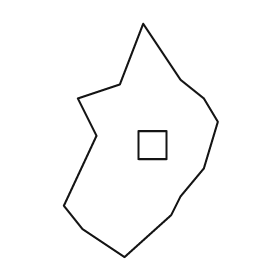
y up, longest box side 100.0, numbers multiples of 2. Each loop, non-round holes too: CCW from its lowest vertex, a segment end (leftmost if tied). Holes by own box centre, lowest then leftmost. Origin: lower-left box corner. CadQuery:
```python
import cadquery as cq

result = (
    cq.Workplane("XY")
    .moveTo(26.0, 0.0)
    .lineTo(46.0, 18.0)
    .lineTo(50.0, 26.0)
    .lineTo(60.0, 38.0)
    .lineTo(66.0, 58.0)
    .lineTo(60.0, 68.0)
    .lineTo(50.0, 76.0)
    .lineTo(34.0, 100.0)
    .lineTo(24.0, 74.0)
    .lineTo(6.0, 68.0)
    .lineTo(14.0, 52.0)
    .lineTo(0.0, 22.0)
    .lineTo(8.0, 12.0)
    .close()
    .moveTo(32.0, 42.0)
    .lineTo(44.0, 42.0)
    .lineTo(44.0, 54.0)
    .lineTo(32.0, 54.0)
    .close()
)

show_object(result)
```